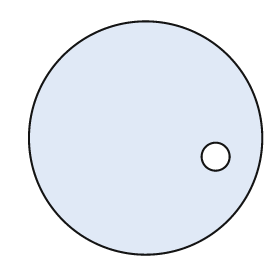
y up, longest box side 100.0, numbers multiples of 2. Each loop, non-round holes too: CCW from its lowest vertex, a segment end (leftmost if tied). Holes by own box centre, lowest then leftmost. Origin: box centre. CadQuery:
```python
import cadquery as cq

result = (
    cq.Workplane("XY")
    .moveTo(0.0, 0.0)
    .circle(50.0)
    .moveTo(30.0, -8.0)
    .circle(6.0)
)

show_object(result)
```